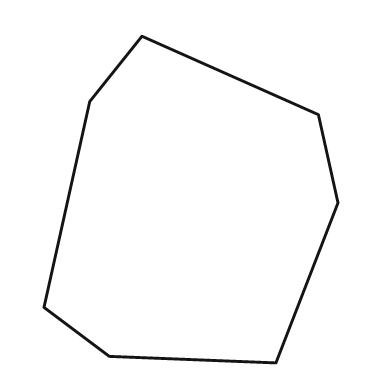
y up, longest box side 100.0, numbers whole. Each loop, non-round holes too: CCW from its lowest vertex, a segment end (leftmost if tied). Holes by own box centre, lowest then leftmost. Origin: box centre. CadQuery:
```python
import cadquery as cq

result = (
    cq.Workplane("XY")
    .moveTo(26.0, -50.0)
    .lineTo(45.0, -1.0)
    .lineTo(39.0, 26.0)
    .lineTo(-15.0, 50.0)
    .lineTo(-31.0, 30.0)
    .lineTo(-45.0, -33.0)
    .lineTo(-25.0, -48.0)
    .close()
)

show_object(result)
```